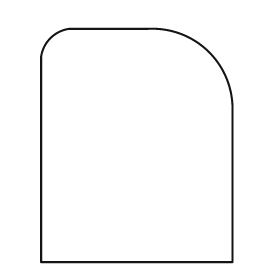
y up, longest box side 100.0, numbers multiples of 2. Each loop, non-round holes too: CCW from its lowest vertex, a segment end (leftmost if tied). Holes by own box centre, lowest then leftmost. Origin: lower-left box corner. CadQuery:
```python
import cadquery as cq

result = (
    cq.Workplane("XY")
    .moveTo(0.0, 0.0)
    .lineTo(82.0, 0.0)
    .lineTo(82.0, 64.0)
    .threePointArc((72.0, 90.0), (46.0, 100.0))
    .lineTo(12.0, 100.0)
    .threePointArc((4.0, 96.0), (0.0, 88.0))
    .close()
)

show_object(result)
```